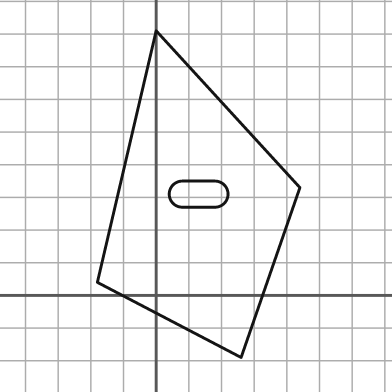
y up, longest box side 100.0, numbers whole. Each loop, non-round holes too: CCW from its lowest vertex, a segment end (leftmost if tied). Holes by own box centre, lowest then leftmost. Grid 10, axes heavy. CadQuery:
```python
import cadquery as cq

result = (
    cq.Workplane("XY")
    .moveTo(26.0, -19.0)
    .lineTo(44.0, 33.0)
    .lineTo(0.0, 81.0)
    .lineTo(-18.0, 4.0)
    .close()
    .moveTo(8.0, 27.0)
    .lineTo(18.0, 27.0)
    .threePointArc((22.0, 31.0), (18.0, 35.0))
    .lineTo(8.0, 35.0)
    .threePointArc((4.0, 31.0), (8.0, 27.0))
    .close()
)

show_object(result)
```